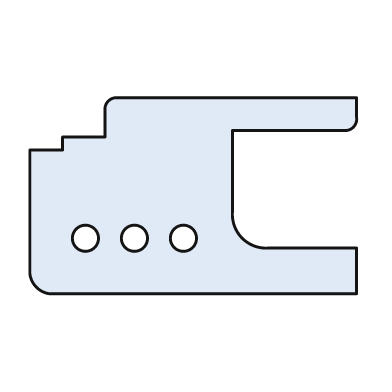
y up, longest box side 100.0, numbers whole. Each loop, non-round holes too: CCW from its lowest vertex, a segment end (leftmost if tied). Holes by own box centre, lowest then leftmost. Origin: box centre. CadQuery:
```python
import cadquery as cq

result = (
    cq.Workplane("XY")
    .moveTo(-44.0, -30.0)
    .lineTo(50.0, -30.0)
    .lineTo(50.0, -16.0)
    .lineTo(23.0, -16.0)
    .threePointArc((15.0, -13.0), (12.0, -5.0))
    .lineTo(12.0, 20.0)
    .lineTo(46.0, 20.0)
    .threePointArc((49.0, 21.0), (50.0, 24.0))
    .lineTo(50.0, 30.0)
    .lineTo(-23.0, 30.0)
    .threePointArc((-26.0, 29.0), (-27.0, 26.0))
    .lineTo(-27.0, 18.0)
    .lineTo(-40.0, 18.0)
    .lineTo(-40.0, 14.0)
    .lineTo(-50.0, 14.0)
    .lineTo(-50.0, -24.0)
    .threePointArc((-48.0, -28.0), (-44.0, -30.0))
    .close()
    .moveTo(-33.0, -13.0)
    .circle(4.0)
    .moveTo(-18.0, -13.0)
    .circle(4.0)
    .moveTo(-3.0, -13.0)
    .circle(4.0)
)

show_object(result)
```